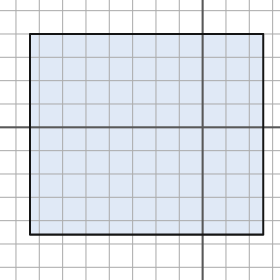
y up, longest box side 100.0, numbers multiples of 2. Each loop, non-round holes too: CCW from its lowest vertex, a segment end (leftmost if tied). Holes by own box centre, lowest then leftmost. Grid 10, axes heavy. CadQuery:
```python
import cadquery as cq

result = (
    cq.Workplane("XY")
    .moveTo(-74.0, -46.0)
    .lineTo(26.0, -46.0)
    .lineTo(26.0, 40.0)
    .lineTo(-74.0, 40.0)
    .close()
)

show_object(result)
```